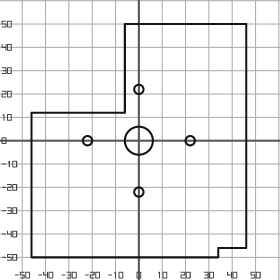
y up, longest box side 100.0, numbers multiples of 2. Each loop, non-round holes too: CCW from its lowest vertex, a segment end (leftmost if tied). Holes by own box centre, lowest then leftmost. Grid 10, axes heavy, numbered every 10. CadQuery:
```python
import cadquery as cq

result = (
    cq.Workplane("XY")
    .moveTo(-46.0, -50.0)
    .lineTo(34.0, -50.0)
    .lineTo(34.0, -46.0)
    .lineTo(46.0, -46.0)
    .lineTo(46.0, 50.0)
    .lineTo(-6.0, 50.0)
    .lineTo(-6.0, 12.0)
    .lineTo(-46.0, 12.0)
    .close()
    .moveTo(0.0, -22.0)
    .circle(2.0)
    .moveTo(-22.0, 0.0)
    .circle(2.0)
    .moveTo(0.0, 0.0)
    .circle(6.0)
    .moveTo(22.0, 0.0)
    .circle(2.0)
    .moveTo(0.0, 22.0)
    .circle(2.0)
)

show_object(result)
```